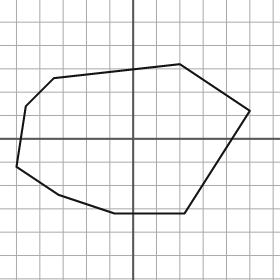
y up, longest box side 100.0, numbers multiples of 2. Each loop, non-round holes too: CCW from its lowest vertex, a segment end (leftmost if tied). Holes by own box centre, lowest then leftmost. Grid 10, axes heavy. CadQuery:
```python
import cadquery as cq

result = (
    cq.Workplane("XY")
    .moveTo(-8.0, -32.0)
    .lineTo(22.0, -32.0)
    .lineTo(50.0, 12.0)
    .lineTo(20.0, 32.0)
    .lineTo(-34.0, 26.0)
    .lineTo(-46.0, 14.0)
    .lineTo(-50.0, -12.0)
    .lineTo(-32.0, -24.0)
    .close()
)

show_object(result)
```